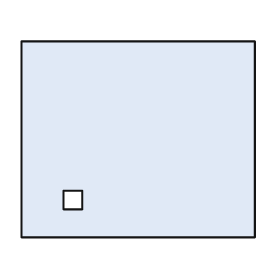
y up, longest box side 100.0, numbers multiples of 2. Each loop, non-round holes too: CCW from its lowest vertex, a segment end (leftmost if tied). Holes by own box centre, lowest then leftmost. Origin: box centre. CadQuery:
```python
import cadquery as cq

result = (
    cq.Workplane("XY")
    .moveTo(-50.0, -42.0)
    .lineTo(50.0, -42.0)
    .lineTo(50.0, 42.0)
    .lineTo(-50.0, 42.0)
    .close()
    .moveTo(-32.0, -30.0)
    .lineTo(-24.0, -30.0)
    .lineTo(-24.0, -22.0)
    .lineTo(-32.0, -22.0)
    .close()
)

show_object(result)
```